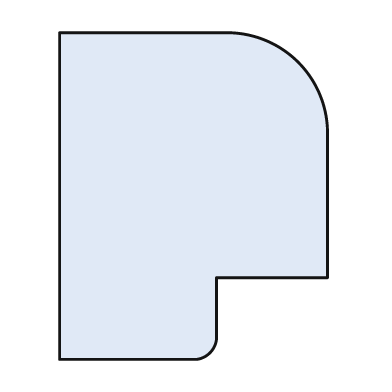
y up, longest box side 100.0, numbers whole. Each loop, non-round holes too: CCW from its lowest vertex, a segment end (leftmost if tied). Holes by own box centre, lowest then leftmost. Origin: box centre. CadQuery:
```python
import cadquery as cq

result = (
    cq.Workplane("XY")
    .moveTo(-41.0, -50.0)
    .lineTo(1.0, -50.0)
    .threePointArc((5.0, -48.0), (7.0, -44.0))
    .lineTo(7.0, -25.0)
    .lineTo(41.0, -25.0)
    .lineTo(41.0, 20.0)
    .threePointArc((32.0, 41.0), (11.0, 50.0))
    .lineTo(-41.0, 50.0)
    .close()
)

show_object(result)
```